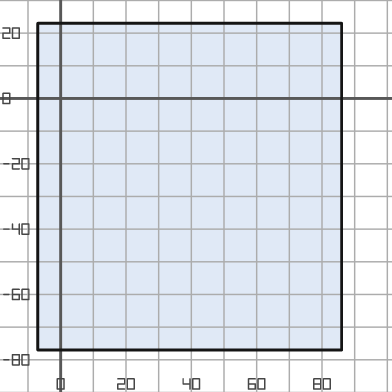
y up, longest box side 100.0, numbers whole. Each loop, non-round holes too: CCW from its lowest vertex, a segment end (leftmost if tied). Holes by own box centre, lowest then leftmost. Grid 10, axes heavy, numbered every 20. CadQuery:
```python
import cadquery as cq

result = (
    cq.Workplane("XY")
    .moveTo(-7.0, -77.0)
    .lineTo(86.0, -77.0)
    .lineTo(86.0, 23.0)
    .lineTo(-7.0, 23.0)
    .close()
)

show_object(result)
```